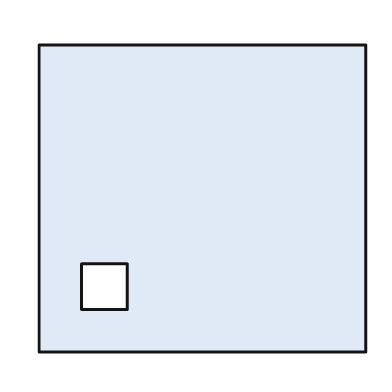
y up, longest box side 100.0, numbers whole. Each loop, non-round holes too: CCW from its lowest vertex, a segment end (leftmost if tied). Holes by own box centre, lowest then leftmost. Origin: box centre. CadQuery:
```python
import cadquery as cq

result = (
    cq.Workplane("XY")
    .moveTo(-50.0, -47.0)
    .lineTo(50.0, -47.0)
    .lineTo(50.0, 47.0)
    .lineTo(-50.0, 47.0)
    .close()
    .moveTo(-37.0, -34.0)
    .lineTo(-23.0, -34.0)
    .lineTo(-23.0, -20.0)
    .lineTo(-37.0, -20.0)
    .close()
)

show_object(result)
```